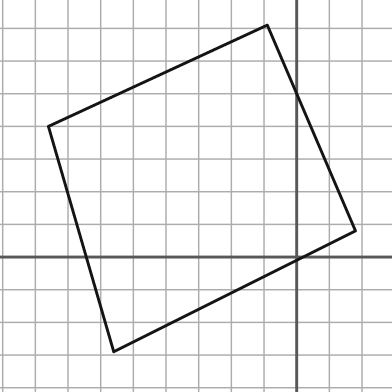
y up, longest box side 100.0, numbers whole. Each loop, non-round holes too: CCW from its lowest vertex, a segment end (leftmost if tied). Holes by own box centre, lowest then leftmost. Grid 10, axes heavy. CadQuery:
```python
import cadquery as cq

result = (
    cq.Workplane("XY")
    .moveTo(-56.0, -29.0)
    .lineTo(18.0, 8.0)
    .lineTo(-9.0, 71.0)
    .lineTo(-76.0, 40.0)
    .close()
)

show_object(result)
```